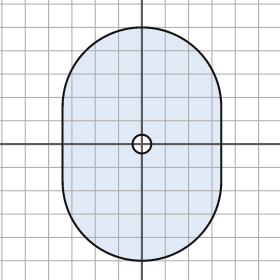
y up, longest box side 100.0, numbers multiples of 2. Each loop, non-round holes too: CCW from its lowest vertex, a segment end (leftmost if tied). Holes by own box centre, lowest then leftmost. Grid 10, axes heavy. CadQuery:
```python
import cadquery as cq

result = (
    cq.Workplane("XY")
    .moveTo(-34.0, -16.0)
    .threePointArc((0.0, -50.0), (34.0, -16.0))
    .lineTo(34.0, 16.0)
    .threePointArc((0.0, 50.0), (-34.0, 16.0))
    .close()
    .moveTo(0.0, 0.0)
    .circle(4.0)
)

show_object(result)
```